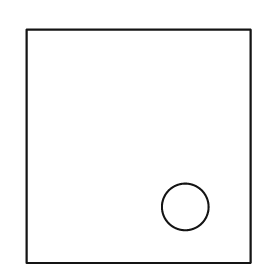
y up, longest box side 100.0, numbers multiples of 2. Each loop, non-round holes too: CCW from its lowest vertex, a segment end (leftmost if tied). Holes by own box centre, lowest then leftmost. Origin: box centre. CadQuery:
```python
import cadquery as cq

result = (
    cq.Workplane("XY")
    .moveTo(-48.0, -50.0)
    .lineTo(48.0, -50.0)
    .lineTo(48.0, 50.0)
    .lineTo(-48.0, 50.0)
    .close()
    .moveTo(20.0, -26.0)
    .circle(10.0)
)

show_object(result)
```